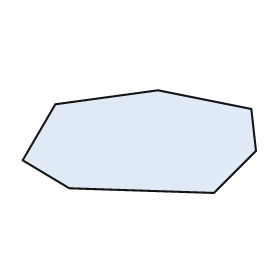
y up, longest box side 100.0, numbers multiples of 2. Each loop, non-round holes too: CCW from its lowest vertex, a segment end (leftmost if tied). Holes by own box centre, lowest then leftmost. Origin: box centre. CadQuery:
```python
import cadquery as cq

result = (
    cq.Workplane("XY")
    .moveTo(32.0, -22.0)
    .lineTo(50.0, -4.0)
    .lineTo(48.0, 14.0)
    .lineTo(8.0, 22.0)
    .lineTo(-36.0, 16.0)
    .lineTo(-50.0, -8.0)
    .lineTo(-30.0, -20.0)
    .close()
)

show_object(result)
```